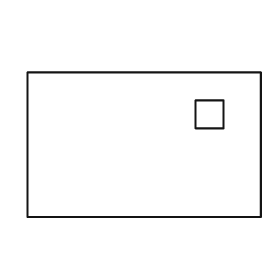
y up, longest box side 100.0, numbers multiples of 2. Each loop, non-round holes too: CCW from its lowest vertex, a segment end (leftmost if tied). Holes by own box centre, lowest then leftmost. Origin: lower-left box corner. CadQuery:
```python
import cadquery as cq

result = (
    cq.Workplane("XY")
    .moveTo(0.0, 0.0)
    .lineTo(100.0, 0.0)
    .lineTo(100.0, 62.0)
    .lineTo(0.0, 62.0)
    .close()
    .moveTo(72.0, 38.0)
    .lineTo(84.0, 38.0)
    .lineTo(84.0, 50.0)
    .lineTo(72.0, 50.0)
    .close()
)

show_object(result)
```